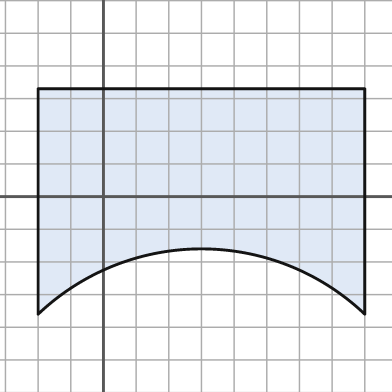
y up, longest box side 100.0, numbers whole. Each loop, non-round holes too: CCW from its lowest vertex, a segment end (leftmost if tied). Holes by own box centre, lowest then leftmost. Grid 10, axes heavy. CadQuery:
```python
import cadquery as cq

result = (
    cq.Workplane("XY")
    .moveTo(-20.0, -36.0)
    .threePointArc((30.0, -16.0), (80.0, -36.0))
    .lineTo(80.0, 33.0)
    .lineTo(-20.0, 33.0)
    .close()
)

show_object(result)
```